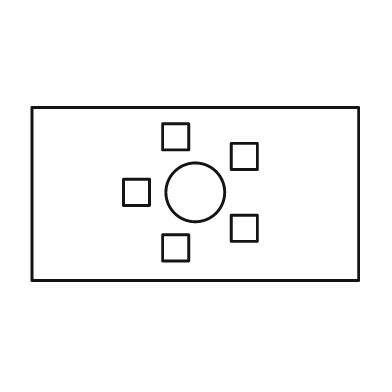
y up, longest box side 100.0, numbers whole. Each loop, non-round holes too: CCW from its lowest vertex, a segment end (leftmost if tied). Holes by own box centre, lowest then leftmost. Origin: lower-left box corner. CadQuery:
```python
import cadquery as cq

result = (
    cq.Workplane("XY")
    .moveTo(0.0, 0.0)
    .lineTo(100.0, 0.0)
    .lineTo(100.0, 53.0)
    .lineTo(0.0, 53.0)
    .close()
    .moveTo(40.0, 6.0)
    .lineTo(48.0, 6.0)
    .lineTo(48.0, 14.0)
    .lineTo(40.0, 14.0)
    .close()
    .moveTo(61.0, 12.0)
    .lineTo(69.0, 12.0)
    .lineTo(69.0, 20.0)
    .lineTo(61.0, 20.0)
    .close()
    .moveTo(28.0, 23.0)
    .lineTo(36.0, 23.0)
    .lineTo(36.0, 31.0)
    .lineTo(28.0, 31.0)
    .close()
    .moveTo(50.0, 27.0)
    .circle(9.0)
    .moveTo(61.0, 34.0)
    .lineTo(69.0, 34.0)
    .lineTo(69.0, 42.0)
    .lineTo(61.0, 42.0)
    .close()
    .moveTo(40.0, 40.0)
    .lineTo(48.0, 40.0)
    .lineTo(48.0, 48.0)
    .lineTo(40.0, 48.0)
    .close()
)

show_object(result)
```